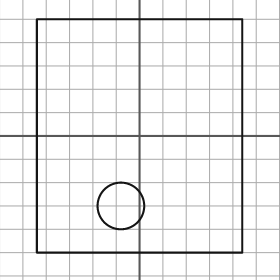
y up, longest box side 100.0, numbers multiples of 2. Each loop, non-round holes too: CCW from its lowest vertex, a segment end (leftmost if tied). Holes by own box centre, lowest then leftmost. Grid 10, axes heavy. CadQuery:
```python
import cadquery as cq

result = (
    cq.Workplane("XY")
    .moveTo(-44.0, -50.0)
    .lineTo(44.0, -50.0)
    .lineTo(44.0, 50.0)
    .lineTo(-44.0, 50.0)
    .close()
    .moveTo(-8.0, -30.0)
    .circle(10.0)
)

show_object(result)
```